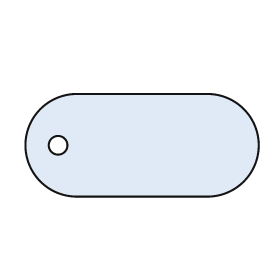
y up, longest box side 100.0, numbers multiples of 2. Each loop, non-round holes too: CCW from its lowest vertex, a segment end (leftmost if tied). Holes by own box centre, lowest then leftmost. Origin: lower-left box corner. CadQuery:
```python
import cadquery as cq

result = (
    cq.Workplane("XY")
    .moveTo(22.0, 0.0)
    .lineTo(78.0, 0.0)
    .threePointArc((100.0, 22.0), (78.0, 44.0))
    .lineTo(22.0, 44.0)
    .threePointArc((0.0, 22.0), (22.0, 0.0))
    .close()
    .moveTo(14.0, 22.0)
    .circle(4.0)
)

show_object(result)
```